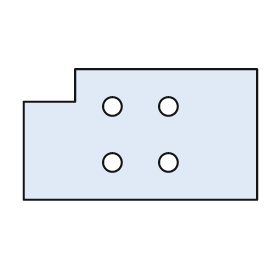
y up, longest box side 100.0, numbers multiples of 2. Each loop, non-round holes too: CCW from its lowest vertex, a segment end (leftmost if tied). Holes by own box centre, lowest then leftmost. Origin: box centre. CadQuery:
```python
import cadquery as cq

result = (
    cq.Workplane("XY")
    .moveTo(-50.0, -28.0)
    .lineTo(50.0, -28.0)
    .lineTo(50.0, 28.0)
    .lineTo(-28.0, 28.0)
    .lineTo(-28.0, 14.0)
    .lineTo(-50.0, 14.0)
    .close()
    .moveTo(-12.0, -12.0)
    .circle(4.0)
    .moveTo(12.0, -12.0)
    .circle(4.0)
    .moveTo(-12.0, 12.0)
    .circle(4.0)
    .moveTo(12.0, 12.0)
    .circle(4.0)
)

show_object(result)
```